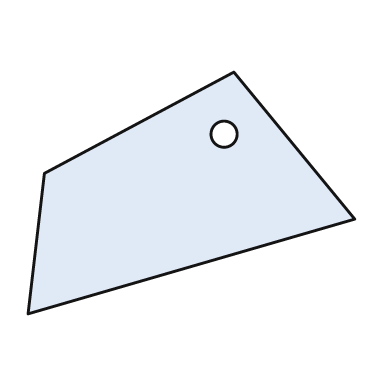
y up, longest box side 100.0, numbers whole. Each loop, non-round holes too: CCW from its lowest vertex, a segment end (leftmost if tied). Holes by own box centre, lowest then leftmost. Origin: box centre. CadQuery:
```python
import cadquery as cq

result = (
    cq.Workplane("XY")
    .moveTo(-50.0, -37.0)
    .lineTo(50.0, -8.0)
    .lineTo(13.0, 37.0)
    .lineTo(-45.0, 6.0)
    .close()
    .moveTo(10.0, 18.0)
    .circle(4.0)
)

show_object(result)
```